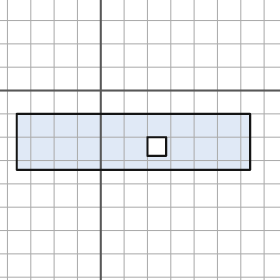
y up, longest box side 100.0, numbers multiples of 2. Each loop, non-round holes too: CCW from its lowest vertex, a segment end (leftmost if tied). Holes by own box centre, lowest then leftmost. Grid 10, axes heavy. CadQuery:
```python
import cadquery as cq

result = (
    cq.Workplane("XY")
    .moveTo(-36.0, -34.0)
    .lineTo(64.0, -34.0)
    .lineTo(64.0, -10.0)
    .lineTo(-36.0, -10.0)
    .close()
    .moveTo(20.0, -28.0)
    .lineTo(28.0, -28.0)
    .lineTo(28.0, -20.0)
    .lineTo(20.0, -20.0)
    .close()
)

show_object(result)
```